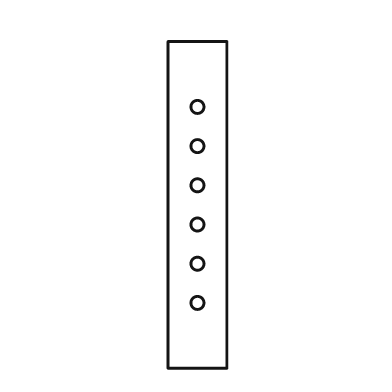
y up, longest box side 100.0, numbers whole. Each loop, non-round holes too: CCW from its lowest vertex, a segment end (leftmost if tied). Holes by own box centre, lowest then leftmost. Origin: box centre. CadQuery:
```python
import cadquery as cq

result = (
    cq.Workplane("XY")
    .moveTo(-9.0, -50.0)
    .lineTo(9.0, -50.0)
    .lineTo(9.0, 50.0)
    .lineTo(-9.0, 50.0)
    .close()
    .moveTo(0.0, -30.0)
    .circle(2.0)
    .moveTo(0.0, -18.0)
    .circle(2.0)
    .moveTo(0.0, -6.0)
    .circle(2.0)
    .moveTo(0.0, 6.0)
    .circle(2.0)
    .moveTo(0.0, 18.0)
    .circle(2.0)
    .moveTo(0.0, 30.0)
    .circle(2.0)
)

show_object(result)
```